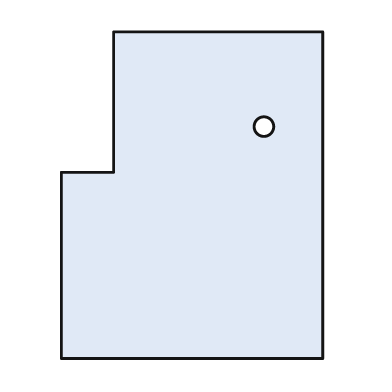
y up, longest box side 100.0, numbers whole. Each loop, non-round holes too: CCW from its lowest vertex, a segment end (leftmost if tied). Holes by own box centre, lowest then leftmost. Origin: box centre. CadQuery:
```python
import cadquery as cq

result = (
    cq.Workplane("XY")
    .moveTo(-40.0, -50.0)
    .lineTo(40.0, -50.0)
    .lineTo(40.0, 50.0)
    .lineTo(-24.0, 50.0)
    .lineTo(-24.0, 7.0)
    .lineTo(-40.0, 7.0)
    .close()
    .moveTo(22.0, 21.0)
    .circle(3.0)
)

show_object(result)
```